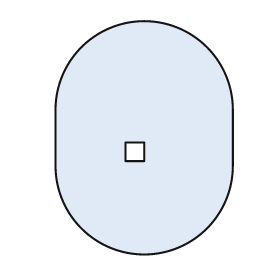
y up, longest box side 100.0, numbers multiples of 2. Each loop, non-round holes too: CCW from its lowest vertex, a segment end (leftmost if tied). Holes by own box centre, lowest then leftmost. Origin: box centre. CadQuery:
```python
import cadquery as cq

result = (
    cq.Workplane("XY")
    .moveTo(-38.0, -12.0)
    .threePointArc((0.0, -50.0), (38.0, -12.0))
    .lineTo(38.0, 12.0)
    .threePointArc((0.0, 50.0), (-38.0, 12.0))
    .close()
    .moveTo(-8.0, -10.0)
    .lineTo(0.0, -10.0)
    .lineTo(0.0, -2.0)
    .lineTo(-8.0, -2.0)
    .close()
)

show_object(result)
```